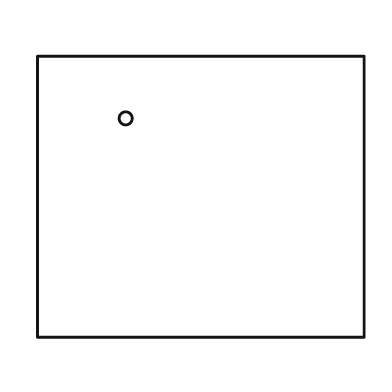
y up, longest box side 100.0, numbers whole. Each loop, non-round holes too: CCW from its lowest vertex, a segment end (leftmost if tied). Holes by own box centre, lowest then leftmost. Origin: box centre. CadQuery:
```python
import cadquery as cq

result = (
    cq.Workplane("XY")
    .moveTo(-50.0, -43.0)
    .lineTo(50.0, -43.0)
    .lineTo(50.0, 43.0)
    .lineTo(-50.0, 43.0)
    .close()
    .moveTo(-23.0, 24.0)
    .circle(2.0)
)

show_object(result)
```